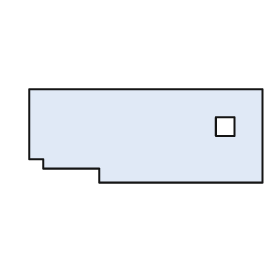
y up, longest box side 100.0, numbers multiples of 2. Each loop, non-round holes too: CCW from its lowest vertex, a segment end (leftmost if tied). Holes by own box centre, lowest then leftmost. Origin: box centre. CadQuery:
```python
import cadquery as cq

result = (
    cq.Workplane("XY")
    .moveTo(-20.0, -20.0)
    .lineTo(50.0, -20.0)
    .lineTo(50.0, 20.0)
    .lineTo(-50.0, 20.0)
    .lineTo(-50.0, -10.0)
    .lineTo(-44.0, -10.0)
    .lineTo(-44.0, -14.0)
    .lineTo(-20.0, -14.0)
    .close()
    .moveTo(30.0, 0.0)
    .lineTo(38.0, 0.0)
    .lineTo(38.0, 8.0)
    .lineTo(30.0, 8.0)
    .close()
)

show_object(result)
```